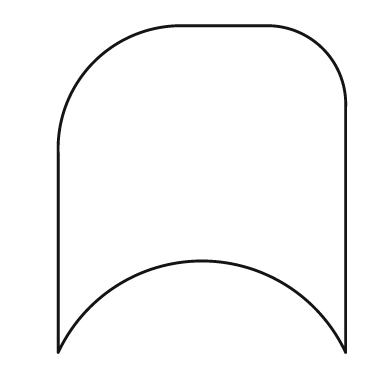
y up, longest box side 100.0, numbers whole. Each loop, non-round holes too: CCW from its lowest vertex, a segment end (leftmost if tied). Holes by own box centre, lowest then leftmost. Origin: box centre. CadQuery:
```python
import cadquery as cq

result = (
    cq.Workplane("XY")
    .moveTo(-44.0, -50.0)
    .threePointArc((0.0, -22.0), (44.0, -50.0))
    .lineTo(44.0, 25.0)
    .threePointArc((37.0, 43.0), (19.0, 50.0))
    .lineTo(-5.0, 50.0)
    .threePointArc((-33.0, 39.0), (-44.0, 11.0))
    .close()
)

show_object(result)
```